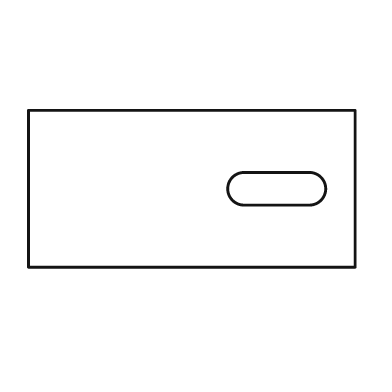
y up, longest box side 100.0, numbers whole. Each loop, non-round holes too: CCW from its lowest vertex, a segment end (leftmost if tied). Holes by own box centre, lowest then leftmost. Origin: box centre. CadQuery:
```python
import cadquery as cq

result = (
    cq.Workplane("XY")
    .moveTo(-50.0, -24.0)
    .lineTo(50.0, -24.0)
    .lineTo(50.0, 24.0)
    .lineTo(-50.0, 24.0)
    .close()
    .moveTo(16.0, -5.0)
    .lineTo(36.0, -5.0)
    .threePointArc((41.0, 0.0), (36.0, 5.0))
    .lineTo(16.0, 5.0)
    .threePointArc((11.0, 0.0), (16.0, -5.0))
    .close()
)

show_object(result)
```